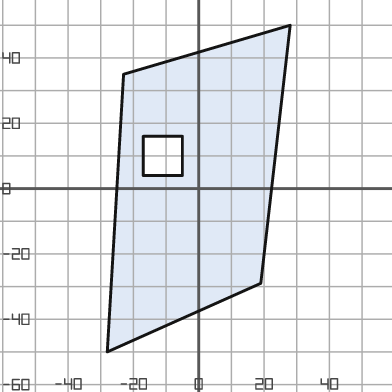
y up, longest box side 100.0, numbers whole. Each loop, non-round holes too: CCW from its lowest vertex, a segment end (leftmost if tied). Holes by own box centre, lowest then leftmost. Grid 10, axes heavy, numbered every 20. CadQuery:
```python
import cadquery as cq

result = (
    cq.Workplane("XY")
    .moveTo(-28.0, -50.0)
    .lineTo(19.0, -29.0)
    .lineTo(28.0, 50.0)
    .lineTo(-23.0, 35.0)
    .close()
    .moveTo(-17.0, 4.0)
    .lineTo(-5.0, 4.0)
    .lineTo(-5.0, 16.0)
    .lineTo(-17.0, 16.0)
    .close()
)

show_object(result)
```